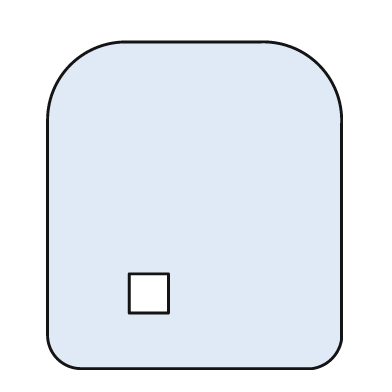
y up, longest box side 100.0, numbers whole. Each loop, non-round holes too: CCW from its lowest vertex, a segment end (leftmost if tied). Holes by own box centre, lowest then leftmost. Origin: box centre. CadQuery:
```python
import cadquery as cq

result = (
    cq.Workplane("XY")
    .moveTo(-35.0, -50.0)
    .lineTo(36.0, -50.0)
    .threePointArc((42.0, -47.0), (45.0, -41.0))
    .lineTo(45.0, 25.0)
    .threePointArc((38.0, 43.0), (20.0, 50.0))
    .lineTo(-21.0, 50.0)
    .threePointArc((-38.0, 43.0), (-45.0, 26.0))
    .lineTo(-45.0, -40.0)
    .threePointArc((-42.0, -47.0), (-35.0, -50.0))
    .close()
    .moveTo(-20.0, -33.0)
    .lineTo(-8.0, -33.0)
    .lineTo(-8.0, -21.0)
    .lineTo(-20.0, -21.0)
    .close()
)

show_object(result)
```